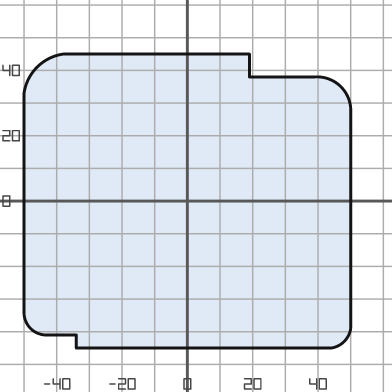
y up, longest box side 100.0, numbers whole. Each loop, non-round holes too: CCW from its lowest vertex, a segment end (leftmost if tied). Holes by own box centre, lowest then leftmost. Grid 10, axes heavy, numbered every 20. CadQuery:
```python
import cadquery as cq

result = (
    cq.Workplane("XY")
    .moveTo(-34.0, -45.0)
    .lineTo(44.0, -45.0)
    .threePointArc((48.0, -43.0), (50.0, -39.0))
    .lineTo(50.0, 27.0)
    .threePointArc((47.0, 35.0), (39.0, 38.0))
    .lineTo(19.0, 38.0)
    .lineTo(19.0, 45.0)
    .lineTo(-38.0, 45.0)
    .threePointArc((-46.0, 41.0), (-50.0, 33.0))
    .lineTo(-50.0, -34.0)
    .threePointArc((-48.0, -39.0), (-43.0, -41.0))
    .lineTo(-34.0, -41.0)
    .close()
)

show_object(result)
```